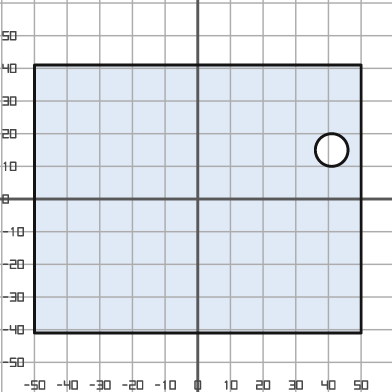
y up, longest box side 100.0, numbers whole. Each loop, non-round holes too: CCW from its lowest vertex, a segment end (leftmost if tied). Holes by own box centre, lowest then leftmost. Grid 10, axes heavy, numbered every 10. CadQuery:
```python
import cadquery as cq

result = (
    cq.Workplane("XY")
    .moveTo(-50.0, -41.0)
    .lineTo(50.0, -41.0)
    .lineTo(50.0, 41.0)
    .lineTo(-50.0, 41.0)
    .close()
    .moveTo(41.0, 15.0)
    .circle(5.0)
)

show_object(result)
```